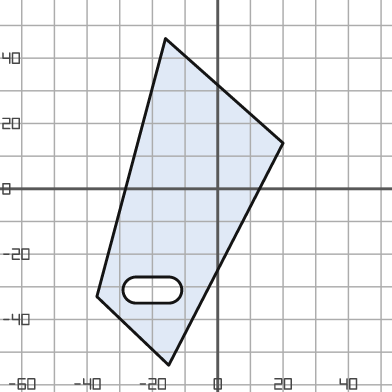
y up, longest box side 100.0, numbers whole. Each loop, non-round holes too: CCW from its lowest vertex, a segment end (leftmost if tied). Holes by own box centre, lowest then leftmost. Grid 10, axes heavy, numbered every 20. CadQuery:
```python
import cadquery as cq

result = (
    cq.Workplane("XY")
    .moveTo(-15.0, -54.0)
    .lineTo(20.0, 14.0)
    .lineTo(-16.0, 46.0)
    .lineTo(-37.0, -33.0)
    .close()
    .moveTo(-25.0, -35.0)
    .lineTo(-15.0, -35.0)
    .threePointArc((-11.0, -31.0), (-15.0, -27.0))
    .lineTo(-25.0, -27.0)
    .threePointArc((-29.0, -31.0), (-25.0, -35.0))
    .close()
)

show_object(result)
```